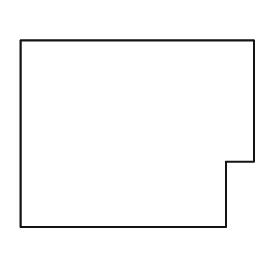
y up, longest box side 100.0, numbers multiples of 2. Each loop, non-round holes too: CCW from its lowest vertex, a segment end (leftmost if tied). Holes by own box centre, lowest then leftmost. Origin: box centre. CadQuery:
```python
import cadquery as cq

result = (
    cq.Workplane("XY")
    .moveTo(-50.0, -40.0)
    .lineTo(38.0, -40.0)
    .lineTo(38.0, -12.0)
    .lineTo(50.0, -12.0)
    .lineTo(50.0, 40.0)
    .lineTo(-50.0, 40.0)
    .close()
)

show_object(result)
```